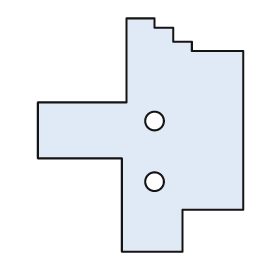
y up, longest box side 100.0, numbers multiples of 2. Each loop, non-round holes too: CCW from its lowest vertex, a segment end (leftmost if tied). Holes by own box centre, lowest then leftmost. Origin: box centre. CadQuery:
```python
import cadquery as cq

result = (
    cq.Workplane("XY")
    .moveTo(-8.0, -50.0)
    .lineTo(18.0, -50.0)
    .lineTo(18.0, -32.0)
    .lineTo(44.0, -32.0)
    .lineTo(44.0, 36.0)
    .lineTo(22.0, 36.0)
    .lineTo(22.0, 40.0)
    .lineTo(14.0, 40.0)
    .lineTo(14.0, 46.0)
    .lineTo(6.0, 46.0)
    .lineTo(6.0, 50.0)
    .lineTo(-6.0, 50.0)
    .lineTo(-6.0, 14.0)
    .lineTo(-44.0, 14.0)
    .lineTo(-44.0, -10.0)
    .lineTo(-8.0, -10.0)
    .close()
    .moveTo(6.0, -20.0)
    .circle(4.0)
    .moveTo(6.0, 6.0)
    .circle(4.0)
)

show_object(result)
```